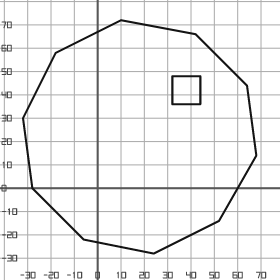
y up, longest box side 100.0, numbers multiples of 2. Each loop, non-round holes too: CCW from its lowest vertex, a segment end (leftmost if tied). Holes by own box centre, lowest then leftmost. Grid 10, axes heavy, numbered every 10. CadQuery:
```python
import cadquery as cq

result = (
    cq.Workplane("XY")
    .moveTo(24.0, -28.0)
    .lineTo(52.0, -14.0)
    .lineTo(68.0, 14.0)
    .lineTo(64.0, 44.0)
    .lineTo(42.0, 66.0)
    .lineTo(10.0, 72.0)
    .lineTo(-18.0, 58.0)
    .lineTo(-32.0, 30.0)
    .lineTo(-28.0, 0.0)
    .lineTo(-6.0, -22.0)
    .close()
    .moveTo(32.0, 36.0)
    .lineTo(44.0, 36.0)
    .lineTo(44.0, 48.0)
    .lineTo(32.0, 48.0)
    .close()
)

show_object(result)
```